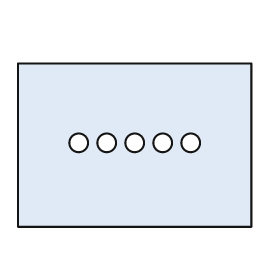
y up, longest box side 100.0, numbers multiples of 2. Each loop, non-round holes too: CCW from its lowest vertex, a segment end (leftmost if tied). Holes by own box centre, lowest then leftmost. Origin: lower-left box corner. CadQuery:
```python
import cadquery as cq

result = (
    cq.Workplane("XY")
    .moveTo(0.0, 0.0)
    .lineTo(100.0, 0.0)
    .lineTo(100.0, 70.0)
    .lineTo(0.0, 70.0)
    .close()
    .moveTo(26.0, 36.0)
    .circle(4.0)
    .moveTo(38.0, 36.0)
    .circle(4.0)
    .moveTo(50.0, 36.0)
    .circle(4.0)
    .moveTo(62.0, 36.0)
    .circle(4.0)
    .moveTo(74.0, 36.0)
    .circle(4.0)
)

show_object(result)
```